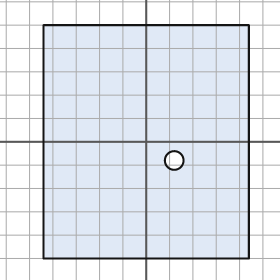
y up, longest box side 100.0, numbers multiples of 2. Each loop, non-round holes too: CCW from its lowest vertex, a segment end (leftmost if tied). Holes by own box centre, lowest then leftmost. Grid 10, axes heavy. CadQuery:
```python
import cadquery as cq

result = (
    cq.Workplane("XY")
    .moveTo(-44.0, -50.0)
    .lineTo(44.0, -50.0)
    .lineTo(44.0, 50.0)
    .lineTo(-44.0, 50.0)
    .close()
    .moveTo(12.0, -8.0)
    .circle(4.0)
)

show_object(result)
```